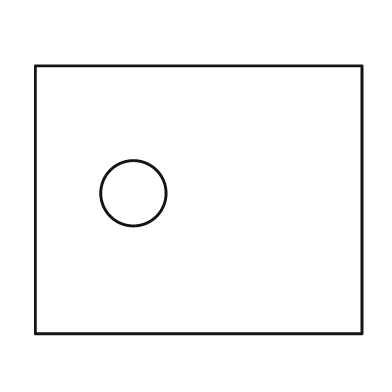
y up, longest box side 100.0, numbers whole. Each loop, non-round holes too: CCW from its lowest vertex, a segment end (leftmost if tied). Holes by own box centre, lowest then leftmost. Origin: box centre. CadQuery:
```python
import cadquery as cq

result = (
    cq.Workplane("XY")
    .moveTo(-50.0, -41.0)
    .lineTo(50.0, -41.0)
    .lineTo(50.0, 41.0)
    .lineTo(-50.0, 41.0)
    .close()
    .moveTo(-20.0, 2.0)
    .circle(10.0)
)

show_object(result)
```